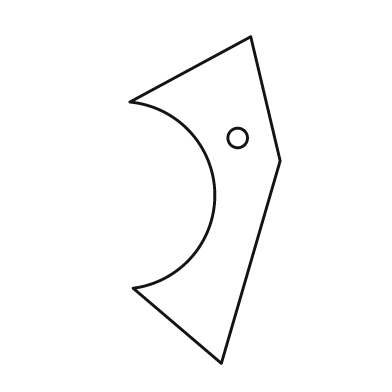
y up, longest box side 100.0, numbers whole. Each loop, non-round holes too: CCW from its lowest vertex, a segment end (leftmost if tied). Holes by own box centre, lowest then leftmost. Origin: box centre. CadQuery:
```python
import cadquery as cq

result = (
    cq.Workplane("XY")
    .moveTo(5.0, -50.0)
    .lineTo(23.0, 12.0)
    .lineTo(14.0, 50.0)
    .lineTo(-23.0, 30.0)
    .threePointArc((3.0, 2.0), (-22.0, -27.0))
    .close()
    .moveTo(10.0, 19.0)
    .circle(3.0)
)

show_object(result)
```